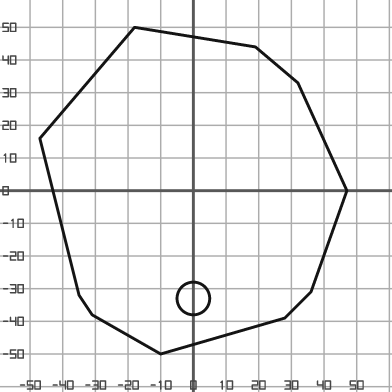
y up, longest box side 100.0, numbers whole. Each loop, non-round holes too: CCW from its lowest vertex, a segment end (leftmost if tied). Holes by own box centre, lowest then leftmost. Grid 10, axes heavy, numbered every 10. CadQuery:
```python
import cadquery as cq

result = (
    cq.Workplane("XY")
    .moveTo(-10.0, -50.0)
    .lineTo(28.0, -39.0)
    .lineTo(36.0, -31.0)
    .lineTo(47.0, 0.0)
    .lineTo(32.0, 33.0)
    .lineTo(19.0, 44.0)
    .lineTo(-18.0, 50.0)
    .lineTo(-47.0, 16.0)
    .lineTo(-35.0, -32.0)
    .lineTo(-31.0, -38.0)
    .close()
    .moveTo(0.0, -33.0)
    .circle(5.0)
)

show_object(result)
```